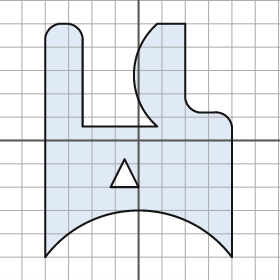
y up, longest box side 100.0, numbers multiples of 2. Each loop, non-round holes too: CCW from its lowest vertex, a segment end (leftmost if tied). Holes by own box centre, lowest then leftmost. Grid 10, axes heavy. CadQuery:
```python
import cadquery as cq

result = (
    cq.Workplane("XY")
    .moveTo(-40.0, -50.0)
    .threePointArc((0.0, -30.0), (40.0, -50.0))
    .lineTo(40.0, 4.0)
    .threePointArc((38.0, 10.0), (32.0, 12.0))
    .lineTo(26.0, 12.0)
    .threePointArc((22.0, 14.0), (20.0, 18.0))
    .lineTo(20.0, 50.0)
    .lineTo(8.0, 50.0)
    .threePointArc((-2.0, 28.0), (8.0, 6.0))
    .lineTo(-24.0, 6.0)
    .lineTo(-24.0, 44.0)
    .threePointArc((-26.0, 48.0), (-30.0, 50.0))
    .lineTo(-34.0, 50.0)
    .threePointArc((-38.0, 48.0), (-40.0, 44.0))
    .close()
    .moveTo(-12.0, -20.0)
    .lineTo(0.0, -20.0)
    .lineTo(-6.0, -8.0)
    .close()
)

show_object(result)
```